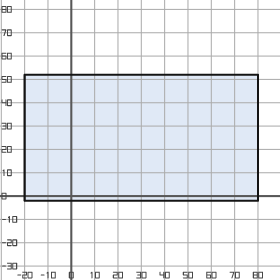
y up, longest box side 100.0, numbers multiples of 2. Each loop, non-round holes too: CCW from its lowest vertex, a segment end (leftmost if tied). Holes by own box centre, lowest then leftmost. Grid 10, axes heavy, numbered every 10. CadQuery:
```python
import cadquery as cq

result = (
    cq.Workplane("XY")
    .moveTo(-20.0, -2.0)
    .lineTo(80.0, -2.0)
    .lineTo(80.0, 52.0)
    .lineTo(-20.0, 52.0)
    .close()
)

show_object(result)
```